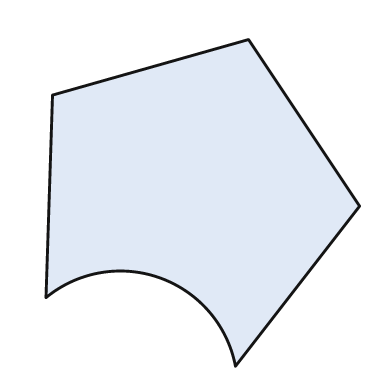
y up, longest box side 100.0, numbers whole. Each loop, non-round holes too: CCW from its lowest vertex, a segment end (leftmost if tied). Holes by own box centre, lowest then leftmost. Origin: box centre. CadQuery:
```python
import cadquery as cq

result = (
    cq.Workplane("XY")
    .moveTo(10.0, -50.0)
    .lineTo(48.0, -1.0)
    .lineTo(14.0, 50.0)
    .lineTo(-46.0, 33.0)
    .lineTo(-48.0, -29.0)
    .threePointArc((-13.0, -23.0), (10.0, -50.0))
    .close()
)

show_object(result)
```